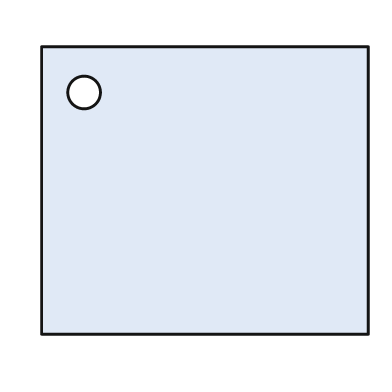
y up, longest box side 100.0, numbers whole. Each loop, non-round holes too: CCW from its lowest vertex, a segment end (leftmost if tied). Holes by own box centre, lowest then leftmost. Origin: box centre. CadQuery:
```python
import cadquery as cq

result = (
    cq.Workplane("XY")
    .moveTo(-50.0, -44.0)
    .lineTo(50.0, -44.0)
    .lineTo(50.0, 44.0)
    .lineTo(-50.0, 44.0)
    .close()
    .moveTo(-37.0, 30.0)
    .circle(5.0)
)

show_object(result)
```